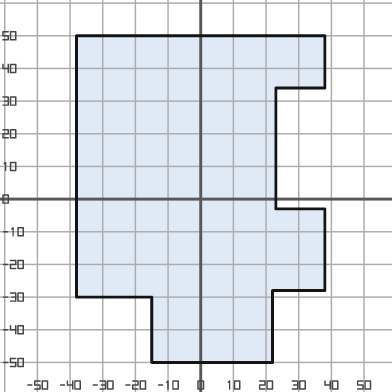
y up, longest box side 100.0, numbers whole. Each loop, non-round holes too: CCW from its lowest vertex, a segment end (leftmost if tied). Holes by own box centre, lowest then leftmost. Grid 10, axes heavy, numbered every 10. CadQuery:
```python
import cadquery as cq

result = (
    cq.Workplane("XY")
    .moveTo(-15.0, -50.0)
    .lineTo(22.0, -50.0)
    .lineTo(22.0, -28.0)
    .lineTo(38.0, -28.0)
    .lineTo(38.0, -3.0)
    .lineTo(23.0, -3.0)
    .lineTo(23.0, 34.0)
    .lineTo(38.0, 34.0)
    .lineTo(38.0, 50.0)
    .lineTo(-38.0, 50.0)
    .lineTo(-38.0, -30.0)
    .lineTo(-15.0, -30.0)
    .close()
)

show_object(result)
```